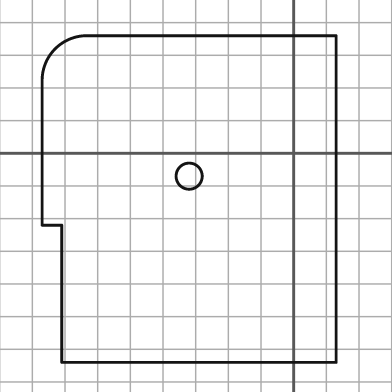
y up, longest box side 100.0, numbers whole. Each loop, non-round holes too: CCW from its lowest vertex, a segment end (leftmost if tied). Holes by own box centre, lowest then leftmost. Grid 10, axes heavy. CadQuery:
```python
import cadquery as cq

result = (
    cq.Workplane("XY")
    .moveTo(-71.0, -64.0)
    .lineTo(13.0, -64.0)
    .lineTo(13.0, 36.0)
    .lineTo(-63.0, 36.0)
    .threePointArc((-73.0, 32.0), (-77.0, 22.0))
    .lineTo(-77.0, -22.0)
    .lineTo(-71.0, -22.0)
    .close()
    .moveTo(-32.0, -7.0)
    .circle(4.0)
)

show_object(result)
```